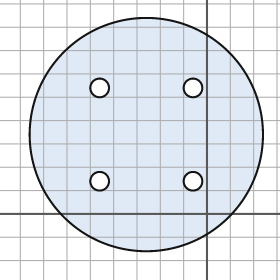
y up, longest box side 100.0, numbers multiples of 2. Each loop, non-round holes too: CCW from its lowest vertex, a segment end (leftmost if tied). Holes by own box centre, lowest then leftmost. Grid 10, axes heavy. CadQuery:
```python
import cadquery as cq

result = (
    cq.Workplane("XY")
    .moveTo(-26.0, 34.0)
    .circle(50.0)
    .moveTo(-46.0, 14.0)
    .circle(4.0)
    .moveTo(-6.0, 14.0)
    .circle(4.0)
    .moveTo(-46.0, 54.0)
    .circle(4.0)
    .moveTo(-6.0, 54.0)
    .circle(4.0)
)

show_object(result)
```